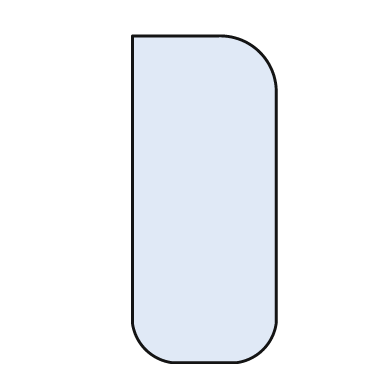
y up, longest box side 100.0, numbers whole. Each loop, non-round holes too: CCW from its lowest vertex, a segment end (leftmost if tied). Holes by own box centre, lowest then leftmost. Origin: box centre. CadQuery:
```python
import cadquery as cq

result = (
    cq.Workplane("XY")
    .moveTo(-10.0, -50.0)
    .lineTo(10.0, -50.0)
    .threePointArc((18.0, -46.0), (22.0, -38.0))
    .lineTo(22.0, 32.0)
    .threePointArc((17.0, 45.0), (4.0, 50.0))
    .lineTo(-22.0, 50.0)
    .lineTo(-22.0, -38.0)
    .threePointArc((-18.0, -46.0), (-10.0, -50.0))
    .close()
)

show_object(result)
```